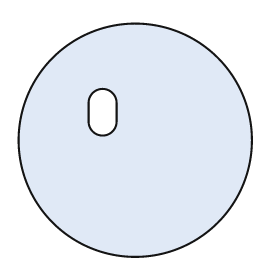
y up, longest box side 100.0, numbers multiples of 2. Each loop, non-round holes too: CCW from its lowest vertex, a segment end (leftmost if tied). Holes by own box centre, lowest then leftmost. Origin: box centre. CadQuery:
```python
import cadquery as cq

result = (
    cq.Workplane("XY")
    .moveTo(0.0, 0.0)
    .circle(50.0)
    .moveTo(-20.0, 8.0)
    .threePointArc((-14.0, 2.0), (-8.0, 8.0))
    .lineTo(-8.0, 16.0)
    .threePointArc((-14.0, 22.0), (-20.0, 16.0))
    .close()
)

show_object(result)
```